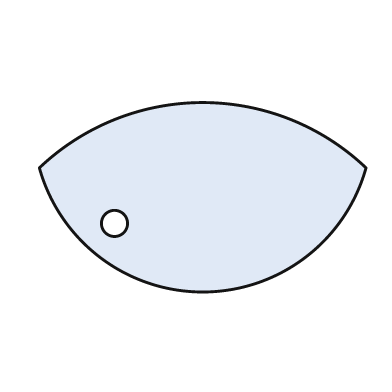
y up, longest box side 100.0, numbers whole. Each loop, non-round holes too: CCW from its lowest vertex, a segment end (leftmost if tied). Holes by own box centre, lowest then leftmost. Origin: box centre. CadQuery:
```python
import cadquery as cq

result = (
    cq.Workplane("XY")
    .moveTo(-50.0, 9.0)
    .threePointArc((0.0, -29.0), (50.0, 9.0))
    .threePointArc((0.0, 29.0), (-50.0, 9.0))
    .close()
    .moveTo(-27.0, -8.0)
    .circle(4.0)
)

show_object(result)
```